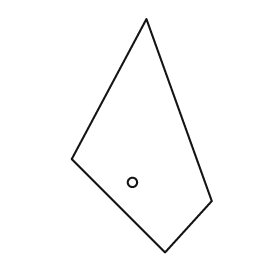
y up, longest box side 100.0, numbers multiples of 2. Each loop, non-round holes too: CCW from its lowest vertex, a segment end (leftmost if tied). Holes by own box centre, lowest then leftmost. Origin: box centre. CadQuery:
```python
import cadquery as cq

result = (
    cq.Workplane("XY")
    .moveTo(10.0, -50.0)
    .lineTo(30.0, -28.0)
    .lineTo(2.0, 50.0)
    .lineTo(-30.0, -10.0)
    .close()
    .moveTo(-4.0, -20.0)
    .circle(2.0)
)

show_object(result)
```